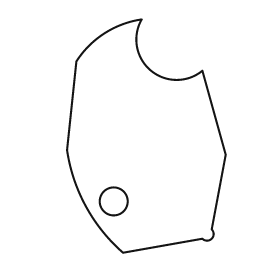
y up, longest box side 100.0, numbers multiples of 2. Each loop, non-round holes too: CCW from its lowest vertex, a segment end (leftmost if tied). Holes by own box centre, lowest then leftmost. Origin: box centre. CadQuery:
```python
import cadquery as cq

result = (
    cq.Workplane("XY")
    .moveTo(-10.0, -50.0)
    .lineTo(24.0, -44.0)
    .threePointArc((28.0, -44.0), (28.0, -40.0))
    .lineTo(34.0, -8.0)
    .lineTo(24.0, 28.0)
    .threePointArc((2.0, 28.0), (-2.0, 50.0))
    .threePointArc((-18.0, 44.0), (-30.0, 32.0))
    .lineTo(-34.0, -6.0)
    .threePointArc((-26.0, -30.0), (-10.0, -50.0))
    .close()
    .moveTo(-14.0, -28.0)
    .circle(6.0)
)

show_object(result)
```